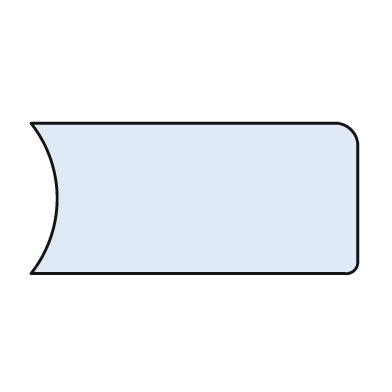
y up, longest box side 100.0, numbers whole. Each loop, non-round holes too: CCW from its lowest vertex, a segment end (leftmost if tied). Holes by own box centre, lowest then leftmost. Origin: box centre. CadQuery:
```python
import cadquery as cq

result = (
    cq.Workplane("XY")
    .moveTo(-50.0, -23.0)
    .lineTo(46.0, -23.0)
    .threePointArc((49.0, -22.0), (50.0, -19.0))
    .lineTo(50.0, 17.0)
    .threePointArc((48.0, 21.0), (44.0, 23.0))
    .lineTo(-50.0, 23.0)
    .threePointArc((-42.0, 0.0), (-50.0, -23.0))
    .close()
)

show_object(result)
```